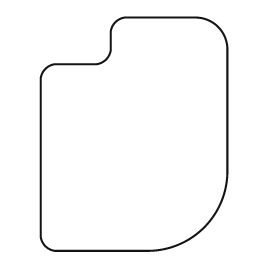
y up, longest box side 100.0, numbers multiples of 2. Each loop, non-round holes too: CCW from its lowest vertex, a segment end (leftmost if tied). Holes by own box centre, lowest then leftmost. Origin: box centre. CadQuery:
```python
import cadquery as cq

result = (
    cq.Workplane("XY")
    .moveTo(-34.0, -50.0)
    .lineTo(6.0, -50.0)
    .threePointArc((30.0, -40.0), (40.0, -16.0))
    .lineTo(40.0, 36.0)
    .threePointArc((36.0, 46.0), (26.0, 50.0))
    .lineTo(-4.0, 50.0)
    .threePointArc((-8.0, 48.0), (-10.0, 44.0))
    .lineTo(-10.0, 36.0)
    .threePointArc((-12.0, 32.0), (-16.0, 30.0))
    .lineTo(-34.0, 30.0)
    .threePointArc((-38.0, 28.0), (-40.0, 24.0))
    .lineTo(-40.0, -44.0)
    .threePointArc((-38.0, -48.0), (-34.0, -50.0))
    .close()
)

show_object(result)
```